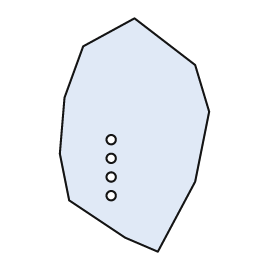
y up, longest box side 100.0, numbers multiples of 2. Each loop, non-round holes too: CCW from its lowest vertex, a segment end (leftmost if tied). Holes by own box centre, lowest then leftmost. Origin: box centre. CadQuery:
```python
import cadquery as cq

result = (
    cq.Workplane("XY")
    .moveTo(10.0, -50.0)
    .lineTo(26.0, -20.0)
    .lineTo(32.0, 10.0)
    .lineTo(26.0, 30.0)
    .lineTo(0.0, 50.0)
    .lineTo(-22.0, 38.0)
    .lineTo(-30.0, 16.0)
    .lineTo(-32.0, -8.0)
    .lineTo(-28.0, -28.0)
    .lineTo(-4.0, -44.0)
    .close()
    .moveTo(-10.0, -26.0)
    .circle(2.0)
    .moveTo(-10.0, -18.0)
    .circle(2.0)
    .moveTo(-10.0, -10.0)
    .circle(2.0)
    .moveTo(-10.0, -2.0)
    .circle(2.0)
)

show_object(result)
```